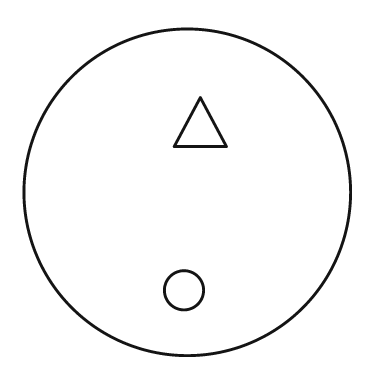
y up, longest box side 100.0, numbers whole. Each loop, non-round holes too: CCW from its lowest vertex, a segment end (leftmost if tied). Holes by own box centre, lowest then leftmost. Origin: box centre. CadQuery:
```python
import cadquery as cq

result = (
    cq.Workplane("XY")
    .moveTo(0.0, 0.0)
    .circle(50.0)
    .moveTo(-1.0, -30.0)
    .circle(6.0)
    .moveTo(-4.0, 14.0)
    .lineTo(12.0, 14.0)
    .lineTo(4.0, 29.0)
    .close()
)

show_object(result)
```